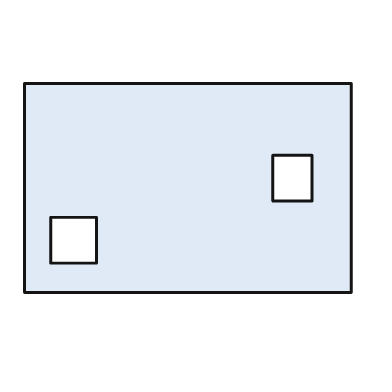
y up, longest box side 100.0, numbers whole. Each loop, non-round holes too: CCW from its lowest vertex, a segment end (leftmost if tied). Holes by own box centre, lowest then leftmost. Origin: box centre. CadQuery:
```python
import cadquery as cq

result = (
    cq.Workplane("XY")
    .moveTo(-50.0, -32.0)
    .lineTo(50.0, -32.0)
    .lineTo(50.0, 32.0)
    .lineTo(-50.0, 32.0)
    .close()
    .moveTo(-42.0, -23.0)
    .lineTo(-28.0, -23.0)
    .lineTo(-28.0, -9.0)
    .lineTo(-42.0, -9.0)
    .close()
    .moveTo(26.0, -4.0)
    .lineTo(38.0, -4.0)
    .lineTo(38.0, 10.0)
    .lineTo(26.0, 10.0)
    .close()
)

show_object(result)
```